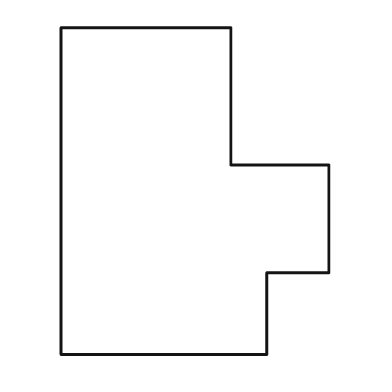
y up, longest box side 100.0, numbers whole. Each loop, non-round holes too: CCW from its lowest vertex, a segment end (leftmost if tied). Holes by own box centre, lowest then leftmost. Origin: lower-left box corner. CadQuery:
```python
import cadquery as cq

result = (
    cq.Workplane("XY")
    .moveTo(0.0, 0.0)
    .lineTo(63.0, 0.0)
    .lineTo(63.0, 25.0)
    .lineTo(82.0, 25.0)
    .lineTo(82.0, 58.0)
    .lineTo(52.0, 58.0)
    .lineTo(52.0, 100.0)
    .lineTo(0.0, 100.0)
    .close()
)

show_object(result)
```